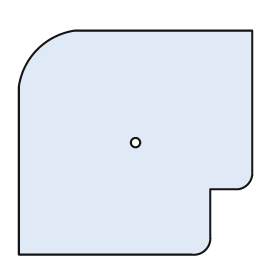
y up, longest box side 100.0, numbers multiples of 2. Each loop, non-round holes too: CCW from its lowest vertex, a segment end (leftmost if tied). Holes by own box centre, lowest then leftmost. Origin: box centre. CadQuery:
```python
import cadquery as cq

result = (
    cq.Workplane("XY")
    .moveTo(-50.0, -48.0)
    .lineTo(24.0, -48.0)
    .threePointArc((30.0, -46.0), (32.0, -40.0))
    .lineTo(32.0, -20.0)
    .lineTo(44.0, -20.0)
    .threePointArc((48.0, -18.0), (50.0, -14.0))
    .lineTo(50.0, 48.0)
    .lineTo(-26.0, 48.0)
    .threePointArc((-42.0, 40.0), (-50.0, 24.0))
    .close()
    .moveTo(0.0, 0.0)
    .circle(2.0)
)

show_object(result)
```